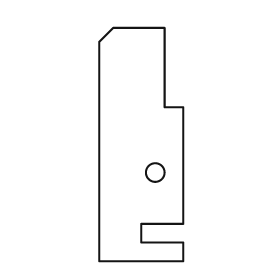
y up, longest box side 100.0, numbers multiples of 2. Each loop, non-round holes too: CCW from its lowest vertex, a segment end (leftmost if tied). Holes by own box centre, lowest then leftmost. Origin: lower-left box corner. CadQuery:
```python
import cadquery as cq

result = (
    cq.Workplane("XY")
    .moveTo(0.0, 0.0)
    .lineTo(36.0, 0.0)
    .lineTo(36.0, 8.0)
    .lineTo(18.0, 8.0)
    .lineTo(18.0, 16.0)
    .lineTo(36.0, 16.0)
    .lineTo(36.0, 66.0)
    .lineTo(28.0, 66.0)
    .lineTo(28.0, 100.0)
    .lineTo(6.0, 100.0)
    .lineTo(0.0, 94.0)
    .close()
    .moveTo(24.0, 38.0)
    .circle(4.0)
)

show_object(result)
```